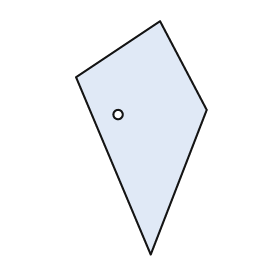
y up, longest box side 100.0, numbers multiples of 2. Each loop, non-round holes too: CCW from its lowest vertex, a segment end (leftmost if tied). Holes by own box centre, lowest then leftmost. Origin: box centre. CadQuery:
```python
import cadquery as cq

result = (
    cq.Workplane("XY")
    .moveTo(4.0, -50.0)
    .lineTo(28.0, 12.0)
    .lineTo(8.0, 50.0)
    .lineTo(-28.0, 26.0)
    .close()
    .moveTo(-10.0, 10.0)
    .circle(2.0)
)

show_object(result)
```